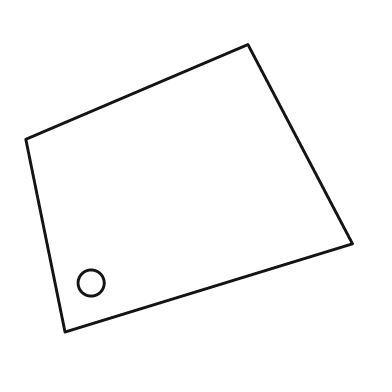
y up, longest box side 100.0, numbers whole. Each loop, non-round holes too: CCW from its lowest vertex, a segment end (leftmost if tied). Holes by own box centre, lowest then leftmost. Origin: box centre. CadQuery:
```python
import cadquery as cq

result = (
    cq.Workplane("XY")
    .moveTo(-38.0, -44.0)
    .lineTo(50.0, -17.0)
    .lineTo(18.0, 44.0)
    .lineTo(-50.0, 15.0)
    .close()
    .moveTo(-30.0, -29.0)
    .circle(4.0)
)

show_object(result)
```